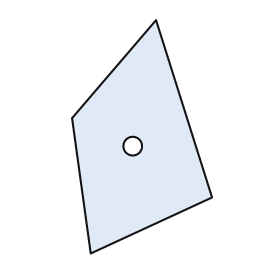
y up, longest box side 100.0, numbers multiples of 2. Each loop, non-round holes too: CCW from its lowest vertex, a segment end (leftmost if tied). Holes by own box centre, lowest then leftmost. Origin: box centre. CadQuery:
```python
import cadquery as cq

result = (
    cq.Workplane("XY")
    .moveTo(-22.0, -50.0)
    .lineTo(30.0, -26.0)
    .lineTo(6.0, 50.0)
    .lineTo(-30.0, 8.0)
    .close()
    .moveTo(-4.0, -4.0)
    .circle(4.0)
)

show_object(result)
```